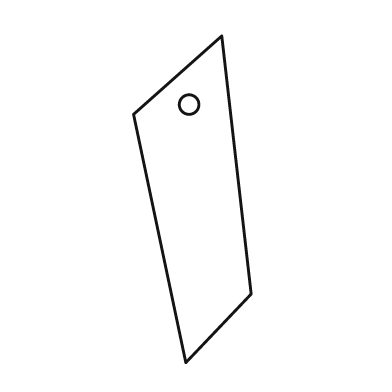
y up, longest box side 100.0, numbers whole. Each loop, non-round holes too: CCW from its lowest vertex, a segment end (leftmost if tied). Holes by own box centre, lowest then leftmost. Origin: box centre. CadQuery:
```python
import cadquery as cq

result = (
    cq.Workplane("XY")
    .moveTo(-2.0, -50.0)
    .lineTo(18.0, -29.0)
    .lineTo(9.0, 50.0)
    .lineTo(-18.0, 26.0)
    .close()
    .moveTo(-1.0, 29.0)
    .circle(3.0)
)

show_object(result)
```